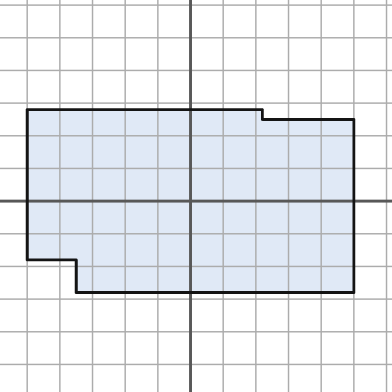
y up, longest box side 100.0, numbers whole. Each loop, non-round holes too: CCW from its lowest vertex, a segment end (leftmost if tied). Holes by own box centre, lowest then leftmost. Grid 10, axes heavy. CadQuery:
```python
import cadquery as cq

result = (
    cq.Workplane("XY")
    .moveTo(-35.0, -28.0)
    .lineTo(50.0, -28.0)
    .lineTo(50.0, 25.0)
    .lineTo(22.0, 25.0)
    .lineTo(22.0, 28.0)
    .lineTo(-50.0, 28.0)
    .lineTo(-50.0, -18.0)
    .lineTo(-35.0, -18.0)
    .close()
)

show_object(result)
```